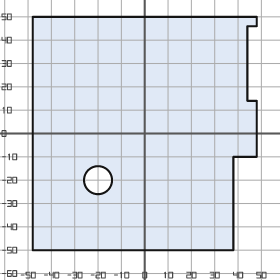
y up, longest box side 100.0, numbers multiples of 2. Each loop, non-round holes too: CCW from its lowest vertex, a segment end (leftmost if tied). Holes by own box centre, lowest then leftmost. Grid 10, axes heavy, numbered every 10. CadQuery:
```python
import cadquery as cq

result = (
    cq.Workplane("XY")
    .moveTo(-48.0, -50.0)
    .lineTo(38.0, -50.0)
    .lineTo(38.0, -10.0)
    .lineTo(48.0, -10.0)
    .lineTo(48.0, 14.0)
    .lineTo(44.0, 14.0)
    .lineTo(44.0, 46.0)
    .lineTo(48.0, 46.0)
    .lineTo(48.0, 50.0)
    .lineTo(-48.0, 50.0)
    .close()
    .moveTo(-20.0, -20.0)
    .circle(6.0)
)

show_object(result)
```